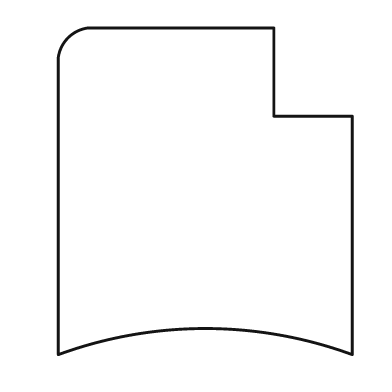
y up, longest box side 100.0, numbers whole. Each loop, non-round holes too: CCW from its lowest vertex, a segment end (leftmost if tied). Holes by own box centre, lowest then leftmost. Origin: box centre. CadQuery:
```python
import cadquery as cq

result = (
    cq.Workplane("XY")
    .moveTo(-45.0, -50.0)
    .threePointArc((0.0, -42.0), (45.0, -50.0))
    .lineTo(45.0, 23.0)
    .lineTo(21.0, 23.0)
    .lineTo(21.0, 50.0)
    .lineTo(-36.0, 50.0)
    .threePointArc((-42.0, 47.0), (-45.0, 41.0))
    .close()
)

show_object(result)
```